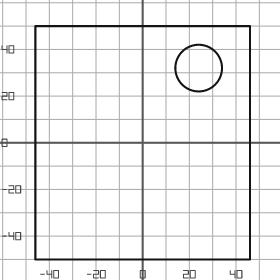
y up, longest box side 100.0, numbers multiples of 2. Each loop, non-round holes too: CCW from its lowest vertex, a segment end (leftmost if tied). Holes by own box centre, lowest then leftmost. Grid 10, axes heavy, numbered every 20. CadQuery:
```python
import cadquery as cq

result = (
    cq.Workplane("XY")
    .moveTo(-46.0, -50.0)
    .lineTo(46.0, -50.0)
    .lineTo(46.0, 50.0)
    .lineTo(-46.0, 50.0)
    .close()
    .moveTo(24.0, 32.0)
    .circle(10.0)
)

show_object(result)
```